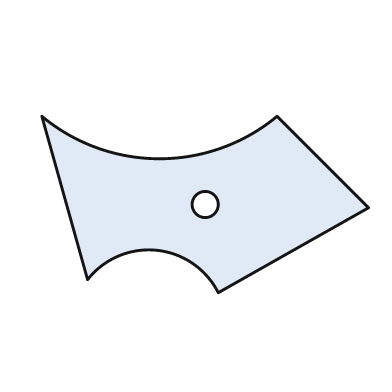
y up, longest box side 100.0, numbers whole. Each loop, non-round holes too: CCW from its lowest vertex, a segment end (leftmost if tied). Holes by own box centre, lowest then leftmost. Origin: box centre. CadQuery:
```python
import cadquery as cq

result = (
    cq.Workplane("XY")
    .moveTo(4.0, -27.0)
    .lineTo(50.0, -1.0)
    .lineTo(22.0, 27.0)
    .threePointArc((-14.0, 14.0), (-50.0, 27.0))
    .lineTo(-36.0, -23.0)
    .threePointArc((-15.0, -14.0), (4.0, -27.0))
    .close()
    .moveTo(0.0, 0.0)
    .circle(4.0)
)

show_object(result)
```